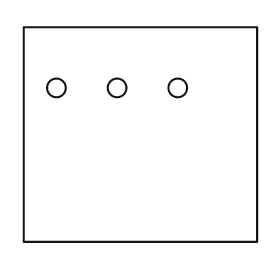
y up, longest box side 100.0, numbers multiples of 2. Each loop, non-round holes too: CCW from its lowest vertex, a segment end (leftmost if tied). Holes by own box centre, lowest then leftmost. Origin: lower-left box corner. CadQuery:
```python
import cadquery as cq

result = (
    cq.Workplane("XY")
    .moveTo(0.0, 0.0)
    .lineTo(100.0, 0.0)
    .lineTo(100.0, 92.0)
    .lineTo(0.0, 92.0)
    .close()
    .moveTo(14.0, 66.0)
    .circle(4.0)
    .moveTo(40.0, 66.0)
    .circle(4.0)
    .moveTo(66.0, 66.0)
    .circle(4.0)
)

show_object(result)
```